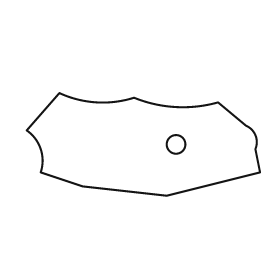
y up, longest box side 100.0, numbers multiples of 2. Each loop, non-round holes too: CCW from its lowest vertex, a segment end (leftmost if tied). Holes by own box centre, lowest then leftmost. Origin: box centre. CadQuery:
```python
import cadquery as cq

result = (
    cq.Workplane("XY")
    .moveTo(10.0, -22.0)
    .lineTo(50.0, -12.0)
    .lineTo(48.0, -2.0)
    .threePointArc((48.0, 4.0), (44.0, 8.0))
    .lineTo(32.0, 18.0)
    .threePointArc((14.0, 16.0), (-4.0, 20.0))
    .threePointArc((-20.0, 18.0), (-36.0, 22.0))
    .lineTo(-50.0, 6.0)
    .threePointArc((-44.0, -2.0), (-44.0, -12.0))
    .lineTo(-26.0, -18.0)
    .close()
    .moveTo(14.0, 0.0)
    .circle(4.0)
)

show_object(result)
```